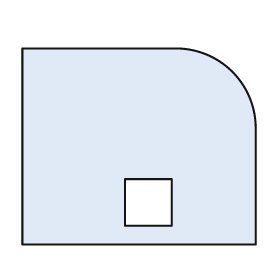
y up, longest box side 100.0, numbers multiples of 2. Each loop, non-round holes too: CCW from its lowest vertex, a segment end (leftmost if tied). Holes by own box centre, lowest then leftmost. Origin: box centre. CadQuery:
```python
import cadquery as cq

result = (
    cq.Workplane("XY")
    .moveTo(-50.0, -42.0)
    .lineTo(50.0, -42.0)
    .lineTo(50.0, 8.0)
    .threePointArc((40.0, 32.0), (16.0, 42.0))
    .lineTo(-50.0, 42.0)
    .close()
    .moveTo(-6.0, -34.0)
    .lineTo(14.0, -34.0)
    .lineTo(14.0, -14.0)
    .lineTo(-6.0, -14.0)
    .close()
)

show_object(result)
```